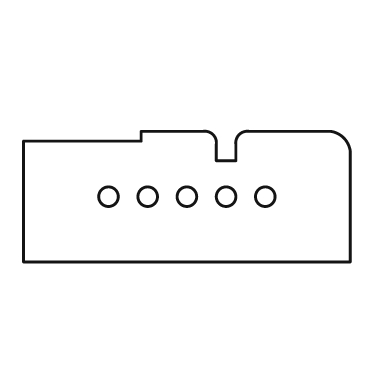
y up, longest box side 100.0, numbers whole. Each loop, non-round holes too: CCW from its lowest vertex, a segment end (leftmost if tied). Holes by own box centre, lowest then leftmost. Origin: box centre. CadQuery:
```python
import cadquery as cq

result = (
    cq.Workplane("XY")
    .moveTo(-50.0, -20.0)
    .lineTo(50.0, -20.0)
    .lineTo(50.0, 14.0)
    .threePointArc((48.0, 18.0), (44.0, 20.0))
    .lineTo(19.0, 20.0)
    .threePointArc((16.0, 19.0), (15.0, 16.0))
    .lineTo(15.0, 11.0)
    .lineTo(9.0, 11.0)
    .lineTo(9.0, 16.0)
    .threePointArc((8.0, 19.0), (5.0, 20.0))
    .lineTo(-14.0, 20.0)
    .lineTo(-14.0, 17.0)
    .lineTo(-50.0, 17.0)
    .close()
    .moveTo(-24.0, 0.0)
    .circle(3.0)
    .moveTo(-12.0, 0.0)
    .circle(3.0)
    .moveTo(0.0, 0.0)
    .circle(3.0)
    .moveTo(12.0, 0.0)
    .circle(3.0)
    .moveTo(24.0, 0.0)
    .circle(3.0)
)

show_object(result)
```